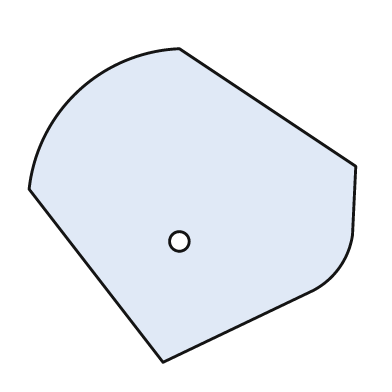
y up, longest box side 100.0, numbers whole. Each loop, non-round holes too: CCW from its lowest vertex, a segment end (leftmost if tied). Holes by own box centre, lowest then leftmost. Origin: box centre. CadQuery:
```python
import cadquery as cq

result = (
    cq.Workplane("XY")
    .moveTo(-9.0, -48.0)
    .lineTo(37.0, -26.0)
    .threePointArc((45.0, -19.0), (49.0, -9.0))
    .lineTo(50.0, 12.0)
    .lineTo(-4.0, 48.0)
    .threePointArc((-35.0, 35.0), (-50.0, 5.0))
    .close()
    .moveTo(-4.0, -11.0)
    .circle(3.0)
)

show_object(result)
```